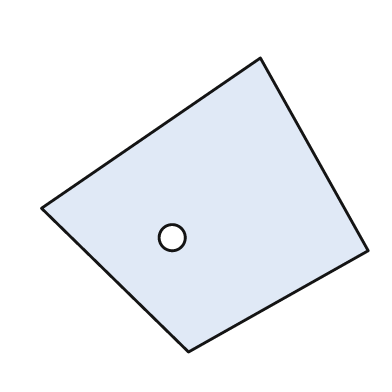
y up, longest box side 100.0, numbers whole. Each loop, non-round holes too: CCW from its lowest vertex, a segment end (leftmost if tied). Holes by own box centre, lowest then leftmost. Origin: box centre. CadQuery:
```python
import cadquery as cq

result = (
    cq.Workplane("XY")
    .moveTo(-5.0, -45.0)
    .lineTo(50.0, -14.0)
    .lineTo(17.0, 45.0)
    .lineTo(-50.0, -1.0)
    .close()
    .moveTo(-10.0, -10.0)
    .circle(4.0)
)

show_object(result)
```